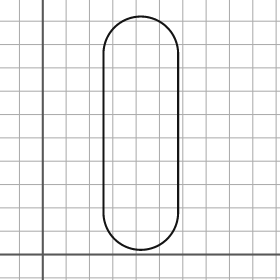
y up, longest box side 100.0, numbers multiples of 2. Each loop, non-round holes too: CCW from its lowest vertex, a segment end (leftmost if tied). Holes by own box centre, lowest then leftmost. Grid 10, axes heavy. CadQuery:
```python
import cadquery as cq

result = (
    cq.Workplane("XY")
    .moveTo(26.0, 18.0)
    .threePointArc((42.0, 2.0), (58.0, 18.0))
    .lineTo(58.0, 86.0)
    .threePointArc((42.0, 102.0), (26.0, 86.0))
    .close()
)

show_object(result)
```